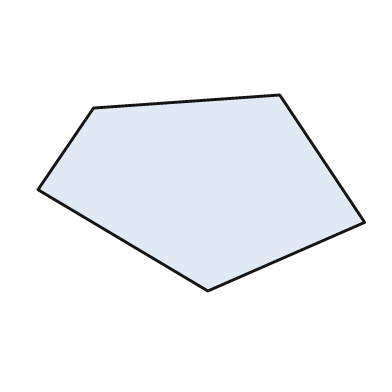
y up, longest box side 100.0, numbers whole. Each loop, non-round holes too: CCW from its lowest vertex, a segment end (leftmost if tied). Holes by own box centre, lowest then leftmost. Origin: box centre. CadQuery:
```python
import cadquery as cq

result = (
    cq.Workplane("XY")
    .moveTo(2.0, -30.0)
    .lineTo(50.0, -9.0)
    .lineTo(24.0, 30.0)
    .lineTo(-33.0, 26.0)
    .lineTo(-50.0, 1.0)
    .close()
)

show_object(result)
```